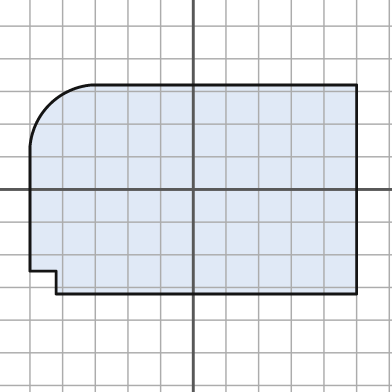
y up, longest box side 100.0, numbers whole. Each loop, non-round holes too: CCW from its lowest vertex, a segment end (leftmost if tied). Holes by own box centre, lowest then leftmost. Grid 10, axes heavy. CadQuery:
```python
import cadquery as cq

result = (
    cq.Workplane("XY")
    .moveTo(-42.0, -32.0)
    .lineTo(50.0, -32.0)
    .lineTo(50.0, 32.0)
    .lineTo(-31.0, 32.0)
    .threePointArc((-44.0, 26.0), (-50.0, 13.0))
    .lineTo(-50.0, -25.0)
    .lineTo(-42.0, -25.0)
    .close()
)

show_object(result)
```